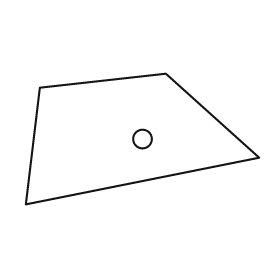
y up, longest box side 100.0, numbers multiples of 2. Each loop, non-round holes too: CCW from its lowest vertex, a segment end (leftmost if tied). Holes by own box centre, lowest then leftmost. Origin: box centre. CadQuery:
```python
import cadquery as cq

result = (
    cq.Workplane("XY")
    .moveTo(-50.0, -28.0)
    .lineTo(50.0, -8.0)
    .lineTo(10.0, 28.0)
    .lineTo(-44.0, 22.0)
    .close()
    .moveTo(0.0, 0.0)
    .circle(4.0)
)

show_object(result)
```